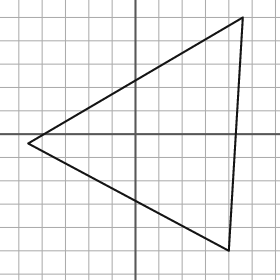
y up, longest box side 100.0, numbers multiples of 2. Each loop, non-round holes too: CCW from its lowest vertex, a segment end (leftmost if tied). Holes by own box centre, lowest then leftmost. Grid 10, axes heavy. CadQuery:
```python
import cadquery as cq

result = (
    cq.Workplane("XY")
    .moveTo(40.0, -50.0)
    .lineTo(46.0, 50.0)
    .lineTo(-46.0, -4.0)
    .close()
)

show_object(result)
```